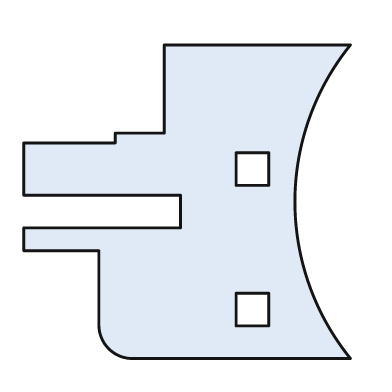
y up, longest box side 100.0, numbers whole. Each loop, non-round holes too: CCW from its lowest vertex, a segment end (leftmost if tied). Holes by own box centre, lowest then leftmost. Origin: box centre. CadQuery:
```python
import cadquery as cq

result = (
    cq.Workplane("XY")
    .moveTo(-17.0, -48.0)
    .lineTo(50.0, -48.0)
    .threePointArc((33.0, 0.0), (50.0, 48.0))
    .lineTo(-7.0, 48.0)
    .lineTo(-7.0, 21.0)
    .lineTo(-22.0, 21.0)
    .lineTo(-22.0, 18.0)
    .lineTo(-50.0, 18.0)
    .lineTo(-50.0, 2.0)
    .lineTo(-2.0, 2.0)
    .lineTo(-2.0, -8.0)
    .lineTo(-50.0, -8.0)
    .lineTo(-50.0, -15.0)
    .lineTo(-27.0, -15.0)
    .lineTo(-27.0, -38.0)
    .threePointArc((-24.0, -45.0), (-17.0, -48.0))
    .close()
    .moveTo(15.0, -38.0)
    .lineTo(25.0, -38.0)
    .lineTo(25.0, -28.0)
    .lineTo(15.0, -28.0)
    .close()
    .moveTo(15.0, 5.0)
    .lineTo(25.0, 5.0)
    .lineTo(25.0, 15.0)
    .lineTo(15.0, 15.0)
    .close()
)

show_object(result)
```